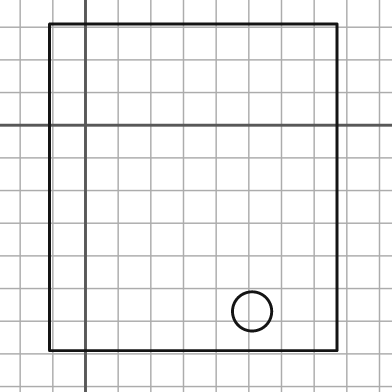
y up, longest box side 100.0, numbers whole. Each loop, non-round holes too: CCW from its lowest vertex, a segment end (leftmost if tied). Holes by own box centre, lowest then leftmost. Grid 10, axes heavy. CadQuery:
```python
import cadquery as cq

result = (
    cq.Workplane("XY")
    .moveTo(-11.0, -69.0)
    .lineTo(77.0, -69.0)
    .lineTo(77.0, 31.0)
    .lineTo(-11.0, 31.0)
    .close()
    .moveTo(51.0, -57.0)
    .circle(6.0)
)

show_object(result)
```